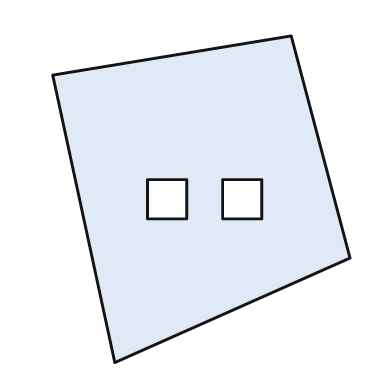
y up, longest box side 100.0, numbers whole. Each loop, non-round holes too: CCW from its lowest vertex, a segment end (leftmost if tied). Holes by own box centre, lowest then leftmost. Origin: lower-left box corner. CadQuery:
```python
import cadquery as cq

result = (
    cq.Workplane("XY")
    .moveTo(19.0, 0.0)
    .lineTo(91.0, 32.0)
    .lineTo(73.0, 100.0)
    .lineTo(0.0, 88.0)
    .close()
    .moveTo(29.0, 44.0)
    .lineTo(41.0, 44.0)
    .lineTo(41.0, 56.0)
    .lineTo(29.0, 56.0)
    .close()
    .moveTo(52.0, 44.0)
    .lineTo(64.0, 44.0)
    .lineTo(64.0, 56.0)
    .lineTo(52.0, 56.0)
    .close()
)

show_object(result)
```